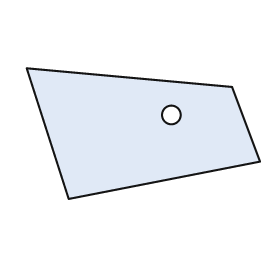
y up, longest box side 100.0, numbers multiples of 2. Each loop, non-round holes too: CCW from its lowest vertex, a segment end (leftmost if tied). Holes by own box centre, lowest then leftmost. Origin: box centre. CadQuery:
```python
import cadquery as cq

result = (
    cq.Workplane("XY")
    .moveTo(-32.0, -28.0)
    .lineTo(50.0, -12.0)
    .lineTo(38.0, 20.0)
    .lineTo(-50.0, 28.0)
    .close()
    .moveTo(12.0, 8.0)
    .circle(4.0)
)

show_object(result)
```